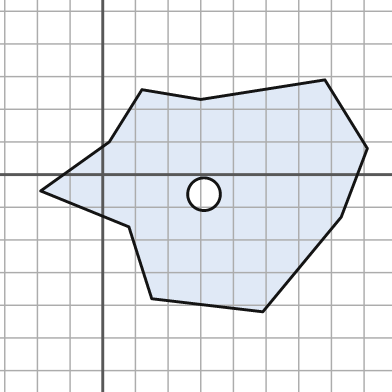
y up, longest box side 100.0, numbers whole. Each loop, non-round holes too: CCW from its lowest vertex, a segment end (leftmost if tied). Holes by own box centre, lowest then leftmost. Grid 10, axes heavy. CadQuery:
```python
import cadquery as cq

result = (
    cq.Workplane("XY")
    .moveTo(49.0, -42.0)
    .lineTo(73.0, -13.0)
    .lineTo(81.0, 8.0)
    .lineTo(68.0, 29.0)
    .lineTo(30.0, 23.0)
    .lineTo(12.0, 26.0)
    .lineTo(2.0, 10.0)
    .lineTo(-19.0, -5.0)
    .lineTo(8.0, -16.0)
    .lineTo(15.0, -38.0)
    .close()
    .moveTo(31.0, -6.0)
    .circle(5.0)
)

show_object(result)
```